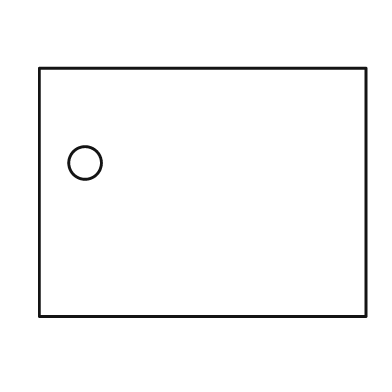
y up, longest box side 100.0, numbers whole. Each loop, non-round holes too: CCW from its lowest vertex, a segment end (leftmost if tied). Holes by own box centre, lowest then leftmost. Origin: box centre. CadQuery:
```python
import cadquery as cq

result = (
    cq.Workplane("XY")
    .moveTo(-50.0, -38.0)
    .lineTo(50.0, -38.0)
    .lineTo(50.0, 38.0)
    .lineTo(-50.0, 38.0)
    .close()
    .moveTo(-36.0, 9.0)
    .circle(5.0)
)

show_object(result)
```